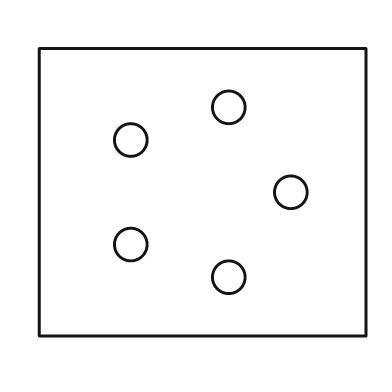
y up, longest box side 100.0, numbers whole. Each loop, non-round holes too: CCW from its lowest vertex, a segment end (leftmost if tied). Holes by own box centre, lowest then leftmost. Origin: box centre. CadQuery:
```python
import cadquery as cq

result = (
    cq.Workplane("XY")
    .moveTo(-50.0, -44.0)
    .lineTo(50.0, -44.0)
    .lineTo(50.0, 44.0)
    .lineTo(-50.0, 44.0)
    .close()
    .moveTo(8.0, -26.0)
    .circle(5.0)
    .moveTo(-22.0, -16.0)
    .circle(5.0)
    .moveTo(27.0, 0.0)
    .circle(5.0)
    .moveTo(-22.0, 16.0)
    .circle(5.0)
    .moveTo(8.0, 26.0)
    .circle(5.0)
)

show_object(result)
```